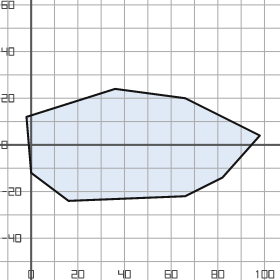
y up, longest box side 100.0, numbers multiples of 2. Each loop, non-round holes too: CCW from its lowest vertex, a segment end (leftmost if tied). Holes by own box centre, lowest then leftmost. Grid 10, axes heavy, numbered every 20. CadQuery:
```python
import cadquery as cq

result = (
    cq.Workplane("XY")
    .moveTo(16.0, -24.0)
    .lineTo(66.0, -22.0)
    .lineTo(82.0, -14.0)
    .lineTo(98.0, 4.0)
    .lineTo(66.0, 20.0)
    .lineTo(36.0, 24.0)
    .lineTo(-2.0, 12.0)
    .lineTo(0.0, -12.0)
    .close()
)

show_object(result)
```